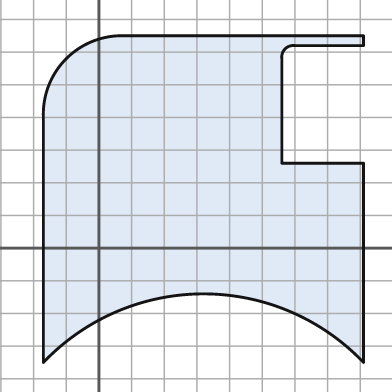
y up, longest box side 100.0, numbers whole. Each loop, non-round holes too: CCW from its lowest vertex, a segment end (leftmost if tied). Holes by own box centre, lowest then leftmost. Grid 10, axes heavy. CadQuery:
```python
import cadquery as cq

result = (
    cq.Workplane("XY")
    .moveTo(-17.0, -35.0)
    .threePointArc((32.0, -14.0), (81.0, -35.0))
    .lineTo(81.0, 26.0)
    .lineTo(56.0, 26.0)
    .lineTo(56.0, 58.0)
    .threePointArc((57.0, 61.0), (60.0, 62.0))
    .lineTo(81.0, 62.0)
    .lineTo(81.0, 65.0)
    .lineTo(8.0, 65.0)
    .threePointArc((-10.0, 58.0), (-17.0, 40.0))
    .close()
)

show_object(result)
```